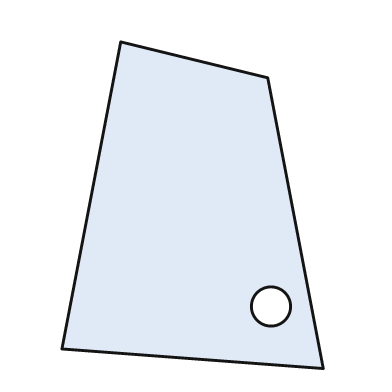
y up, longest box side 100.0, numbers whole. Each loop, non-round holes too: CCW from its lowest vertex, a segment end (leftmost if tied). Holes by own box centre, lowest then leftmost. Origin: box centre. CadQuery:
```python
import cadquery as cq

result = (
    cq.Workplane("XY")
    .moveTo(40.0, -50.0)
    .lineTo(23.0, 39.0)
    .lineTo(-22.0, 50.0)
    .lineTo(-40.0, -44.0)
    .close()
    .moveTo(24.0, -31.0)
    .circle(6.0)
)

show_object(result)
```